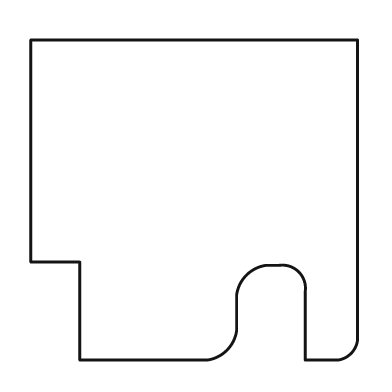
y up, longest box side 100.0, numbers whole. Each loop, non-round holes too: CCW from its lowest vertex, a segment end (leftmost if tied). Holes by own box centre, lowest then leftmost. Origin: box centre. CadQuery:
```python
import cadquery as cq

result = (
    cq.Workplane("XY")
    .moveTo(-35.0, -49.0)
    .lineTo(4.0, -49.0)
    .threePointArc((10.0, -46.0), (13.0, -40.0))
    .lineTo(13.0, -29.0)
    .threePointArc((16.0, -23.0), (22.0, -20.0))
    .lineTo(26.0, -20.0)
    .threePointArc((32.0, -22.0), (34.0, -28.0))
    .lineTo(34.0, -49.0)
    .lineTo(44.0, -49.0)
    .threePointArc((48.0, -47.0), (50.0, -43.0))
    .lineTo(50.0, 49.0)
    .lineTo(-50.0, 49.0)
    .lineTo(-50.0, -19.0)
    .lineTo(-35.0, -19.0)
    .close()
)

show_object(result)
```